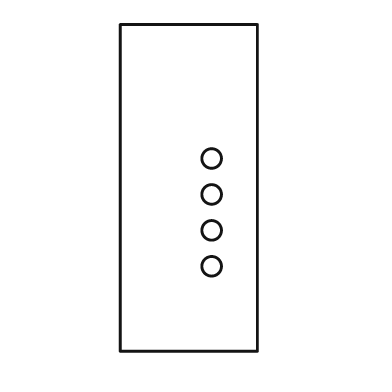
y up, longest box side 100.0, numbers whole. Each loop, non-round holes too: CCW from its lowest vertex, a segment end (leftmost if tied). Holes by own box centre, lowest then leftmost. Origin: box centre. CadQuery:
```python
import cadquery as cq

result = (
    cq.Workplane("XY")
    .moveTo(-21.0, -50.0)
    .lineTo(21.0, -50.0)
    .lineTo(21.0, 50.0)
    .lineTo(-21.0, 50.0)
    .close()
    .moveTo(7.0, -24.0)
    .circle(3.0)
    .moveTo(7.0, -13.0)
    .circle(3.0)
    .moveTo(7.0, -2.0)
    .circle(3.0)
    .moveTo(7.0, 9.0)
    .circle(3.0)
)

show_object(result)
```